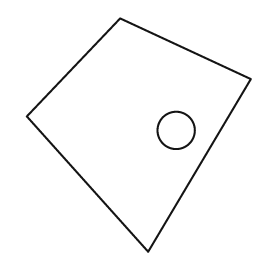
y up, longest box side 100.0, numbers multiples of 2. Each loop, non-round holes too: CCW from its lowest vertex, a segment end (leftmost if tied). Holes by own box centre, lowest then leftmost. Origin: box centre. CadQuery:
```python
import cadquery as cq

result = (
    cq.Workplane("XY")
    .moveTo(4.0, -50.0)
    .lineTo(48.0, 24.0)
    .lineTo(-8.0, 50.0)
    .lineTo(-48.0, 8.0)
    .close()
    .moveTo(16.0, 2.0)
    .circle(8.0)
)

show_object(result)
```